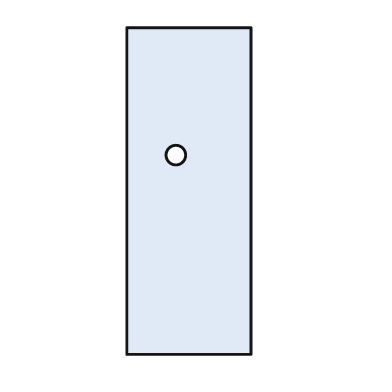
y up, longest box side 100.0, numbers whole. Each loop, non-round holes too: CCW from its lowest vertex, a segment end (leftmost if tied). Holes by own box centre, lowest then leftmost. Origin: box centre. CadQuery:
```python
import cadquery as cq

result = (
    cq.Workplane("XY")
    .moveTo(-19.0, -50.0)
    .lineTo(19.0, -50.0)
    .lineTo(19.0, 50.0)
    .lineTo(-19.0, 50.0)
    .close()
    .moveTo(-4.0, 11.0)
    .circle(3.0)
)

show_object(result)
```